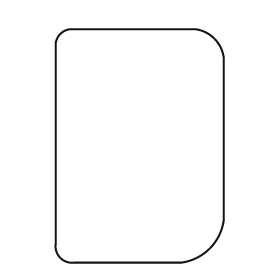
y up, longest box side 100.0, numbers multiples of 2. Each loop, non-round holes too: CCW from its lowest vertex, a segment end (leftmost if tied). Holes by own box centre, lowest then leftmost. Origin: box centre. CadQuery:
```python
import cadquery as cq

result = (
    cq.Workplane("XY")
    .moveTo(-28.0, -50.0)
    .lineTo(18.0, -50.0)
    .threePointArc((30.0, -44.0), (36.0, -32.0))
    .lineTo(36.0, 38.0)
    .threePointArc((32.0, 46.0), (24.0, 50.0))
    .lineTo(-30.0, 50.0)
    .threePointArc((-34.0, 48.0), (-36.0, 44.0))
    .lineTo(-36.0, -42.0)
    .threePointArc((-34.0, -48.0), (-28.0, -50.0))
    .close()
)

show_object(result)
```